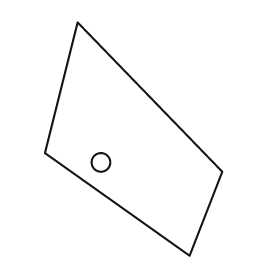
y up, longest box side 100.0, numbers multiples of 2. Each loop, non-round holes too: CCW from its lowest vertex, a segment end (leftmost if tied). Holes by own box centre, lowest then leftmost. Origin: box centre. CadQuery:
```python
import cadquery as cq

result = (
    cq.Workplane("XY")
    .moveTo(24.0, -50.0)
    .lineTo(38.0, -14.0)
    .lineTo(-24.0, 50.0)
    .lineTo(-38.0, -6.0)
    .close()
    .moveTo(-14.0, -10.0)
    .circle(4.0)
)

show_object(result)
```